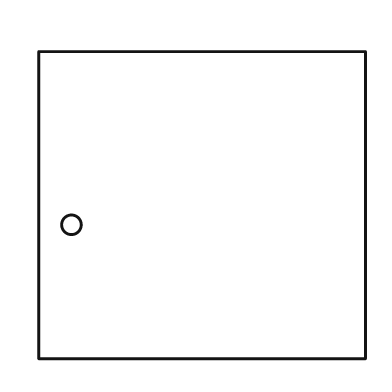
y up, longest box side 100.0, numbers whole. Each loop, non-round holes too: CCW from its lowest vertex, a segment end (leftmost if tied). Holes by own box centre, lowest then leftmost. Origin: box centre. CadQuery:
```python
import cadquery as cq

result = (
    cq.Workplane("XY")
    .moveTo(-50.0, -47.0)
    .lineTo(50.0, -47.0)
    .lineTo(50.0, 47.0)
    .lineTo(-50.0, 47.0)
    .close()
    .moveTo(-40.0, -6.0)
    .circle(3.0)
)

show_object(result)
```